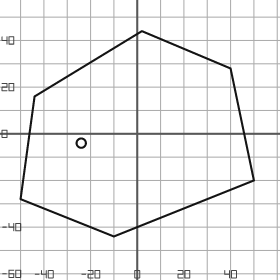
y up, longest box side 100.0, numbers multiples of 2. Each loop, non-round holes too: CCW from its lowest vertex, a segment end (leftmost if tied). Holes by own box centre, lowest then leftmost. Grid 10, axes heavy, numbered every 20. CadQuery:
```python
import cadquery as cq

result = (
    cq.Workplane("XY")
    .moveTo(-10.0, -44.0)
    .lineTo(50.0, -20.0)
    .lineTo(40.0, 28.0)
    .lineTo(2.0, 44.0)
    .lineTo(-44.0, 16.0)
    .lineTo(-50.0, -28.0)
    .close()
    .moveTo(-24.0, -4.0)
    .circle(2.0)
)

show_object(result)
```